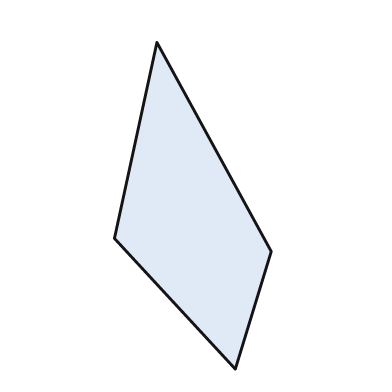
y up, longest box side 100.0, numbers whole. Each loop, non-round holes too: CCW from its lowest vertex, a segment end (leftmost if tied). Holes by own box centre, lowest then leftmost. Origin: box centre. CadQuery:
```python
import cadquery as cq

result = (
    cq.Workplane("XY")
    .moveTo(13.0, -50.0)
    .lineTo(24.0, -14.0)
    .lineTo(-11.0, 50.0)
    .lineTo(-24.0, -10.0)
    .close()
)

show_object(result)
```